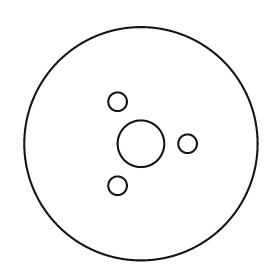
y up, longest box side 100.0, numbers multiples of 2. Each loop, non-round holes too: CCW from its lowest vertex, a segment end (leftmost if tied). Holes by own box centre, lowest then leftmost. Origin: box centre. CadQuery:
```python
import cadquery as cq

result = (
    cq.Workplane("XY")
    .moveTo(0.0, 0.0)
    .circle(50.0)
    .moveTo(-10.0, -18.0)
    .circle(4.0)
    .moveTo(0.0, 0.0)
    .circle(10.0)
    .moveTo(20.0, 0.0)
    .circle(4.0)
    .moveTo(-10.0, 18.0)
    .circle(4.0)
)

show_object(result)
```